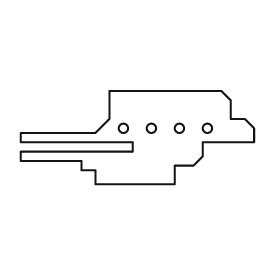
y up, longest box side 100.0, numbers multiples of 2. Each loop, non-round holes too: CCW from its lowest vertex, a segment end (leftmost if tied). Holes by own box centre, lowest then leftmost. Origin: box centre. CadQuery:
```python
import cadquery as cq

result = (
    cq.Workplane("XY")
    .moveTo(-18.0, -20.0)
    .lineTo(16.0, -20.0)
    .lineTo(16.0, -12.0)
    .lineTo(24.0, -12.0)
    .lineTo(28.0, -8.0)
    .lineTo(28.0, -2.0)
    .lineTo(50.0, -2.0)
    .lineTo(50.0, 4.0)
    .lineTo(46.0, 8.0)
    .lineTo(40.0, 8.0)
    .lineTo(40.0, 16.0)
    .lineTo(36.0, 20.0)
    .lineTo(-12.0, 20.0)
    .lineTo(-12.0, 8.0)
    .lineTo(-18.0, 2.0)
    .lineTo(-50.0, 2.0)
    .lineTo(-50.0, -2.0)
    .lineTo(-2.0, -2.0)
    .lineTo(-2.0, -6.0)
    .lineTo(-50.0, -6.0)
    .lineTo(-50.0, -10.0)
    .lineTo(-24.0, -10.0)
    .lineTo(-24.0, -14.0)
    .lineTo(-18.0, -14.0)
    .close()
    .moveTo(-6.0, 4.0)
    .circle(2.0)
    .moveTo(6.0, 4.0)
    .circle(2.0)
    .moveTo(18.0, 4.0)
    .circle(2.0)
    .moveTo(30.0, 4.0)
    .circle(2.0)
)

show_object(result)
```